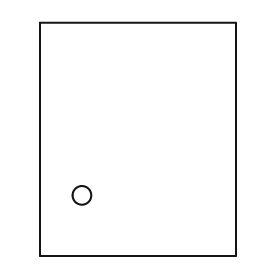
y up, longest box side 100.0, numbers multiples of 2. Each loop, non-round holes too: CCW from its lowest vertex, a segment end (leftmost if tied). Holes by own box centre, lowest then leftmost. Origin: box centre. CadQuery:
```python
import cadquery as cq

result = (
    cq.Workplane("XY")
    .moveTo(-42.0, -50.0)
    .lineTo(42.0, -50.0)
    .lineTo(42.0, 50.0)
    .lineTo(-42.0, 50.0)
    .close()
    .moveTo(-24.0, -24.0)
    .circle(4.0)
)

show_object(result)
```